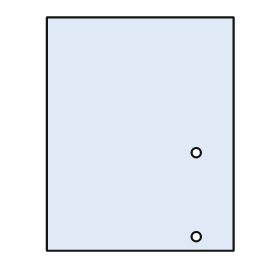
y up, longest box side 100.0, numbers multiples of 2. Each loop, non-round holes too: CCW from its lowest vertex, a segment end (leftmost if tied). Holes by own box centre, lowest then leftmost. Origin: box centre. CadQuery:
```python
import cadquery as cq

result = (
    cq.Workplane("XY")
    .moveTo(-40.0, -50.0)
    .lineTo(40.0, -50.0)
    .lineTo(40.0, 50.0)
    .lineTo(-40.0, 50.0)
    .close()
    .moveTo(24.0, -44.0)
    .circle(2.0)
    .moveTo(24.0, -8.0)
    .circle(2.0)
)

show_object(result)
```